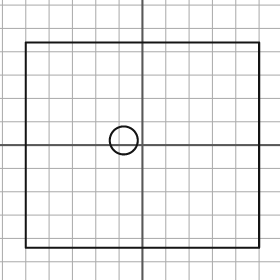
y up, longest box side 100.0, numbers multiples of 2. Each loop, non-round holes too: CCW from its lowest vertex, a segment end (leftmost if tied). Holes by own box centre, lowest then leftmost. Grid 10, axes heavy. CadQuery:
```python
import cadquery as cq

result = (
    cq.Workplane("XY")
    .moveTo(-50.0, -44.0)
    .lineTo(50.0, -44.0)
    .lineTo(50.0, 44.0)
    .lineTo(-50.0, 44.0)
    .close()
    .moveTo(-8.0, 2.0)
    .circle(6.0)
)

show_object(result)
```